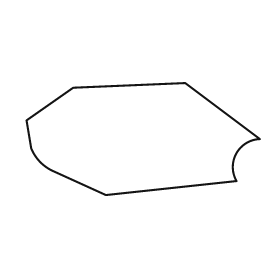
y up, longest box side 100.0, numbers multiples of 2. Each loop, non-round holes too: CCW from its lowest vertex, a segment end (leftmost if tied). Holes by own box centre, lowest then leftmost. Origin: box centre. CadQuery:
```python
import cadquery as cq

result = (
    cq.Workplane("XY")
    .moveTo(-16.0, -24.0)
    .lineTo(40.0, -18.0)
    .threePointArc((40.0, -6.0), (50.0, 0.0))
    .lineTo(18.0, 24.0)
    .lineTo(-30.0, 22.0)
    .lineTo(-50.0, 8.0)
    .lineTo(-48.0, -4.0)
    .threePointArc((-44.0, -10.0), (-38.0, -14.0))
    .close()
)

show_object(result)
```